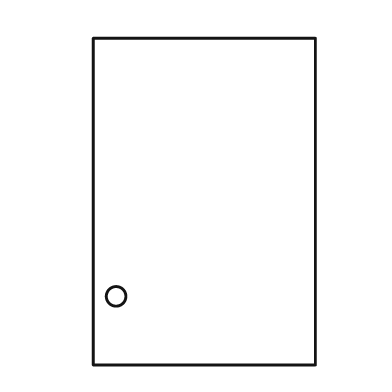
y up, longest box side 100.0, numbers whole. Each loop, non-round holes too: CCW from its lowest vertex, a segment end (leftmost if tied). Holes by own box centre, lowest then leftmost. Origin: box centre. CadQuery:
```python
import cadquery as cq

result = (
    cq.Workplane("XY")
    .moveTo(-34.0, -50.0)
    .lineTo(34.0, -50.0)
    .lineTo(34.0, 50.0)
    .lineTo(-34.0, 50.0)
    .close()
    .moveTo(-27.0, -29.0)
    .circle(3.0)
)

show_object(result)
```